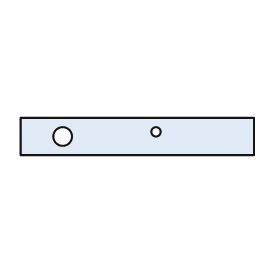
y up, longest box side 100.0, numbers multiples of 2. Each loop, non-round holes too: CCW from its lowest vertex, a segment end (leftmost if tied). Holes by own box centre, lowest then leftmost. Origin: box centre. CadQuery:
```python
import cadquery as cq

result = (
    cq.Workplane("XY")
    .moveTo(-50.0, -8.0)
    .lineTo(50.0, -8.0)
    .lineTo(50.0, 8.0)
    .lineTo(-50.0, 8.0)
    .close()
    .moveTo(-32.0, 0.0)
    .circle(4.0)
    .moveTo(8.0, 2.0)
    .circle(2.0)
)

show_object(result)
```